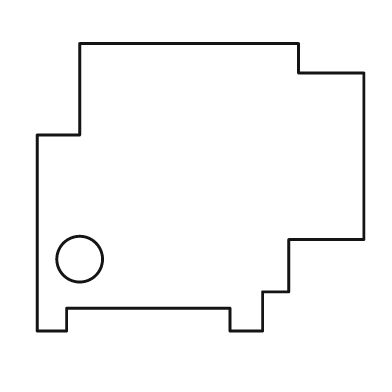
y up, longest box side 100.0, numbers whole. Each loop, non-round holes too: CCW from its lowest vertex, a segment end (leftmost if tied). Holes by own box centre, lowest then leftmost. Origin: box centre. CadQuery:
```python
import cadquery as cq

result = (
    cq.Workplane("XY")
    .moveTo(-50.0, -44.0)
    .lineTo(-41.0, -44.0)
    .lineTo(-41.0, -37.0)
    .lineTo(9.0, -37.0)
    .lineTo(9.0, -44.0)
    .lineTo(19.0, -44.0)
    .lineTo(19.0, -32.0)
    .lineTo(27.0, -32.0)
    .lineTo(27.0, -16.0)
    .lineTo(50.0, -16.0)
    .lineTo(50.0, 35.0)
    .lineTo(30.0, 35.0)
    .lineTo(30.0, 44.0)
    .lineTo(-37.0, 44.0)
    .lineTo(-37.0, 16.0)
    .lineTo(-50.0, 16.0)
    .close()
    .moveTo(-37.0, -22.0)
    .circle(7.0)
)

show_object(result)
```